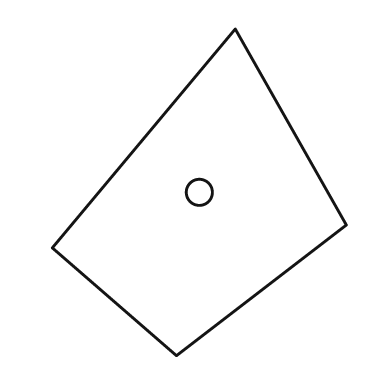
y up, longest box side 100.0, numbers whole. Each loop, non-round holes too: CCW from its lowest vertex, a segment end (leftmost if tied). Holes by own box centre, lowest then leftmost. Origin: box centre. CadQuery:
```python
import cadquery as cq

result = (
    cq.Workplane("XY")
    .moveTo(-7.0, -50.0)
    .lineTo(45.0, -10.0)
    .lineTo(11.0, 50.0)
    .lineTo(-45.0, -17.0)
    .close()
    .moveTo(0.0, 0.0)
    .circle(4.0)
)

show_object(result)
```